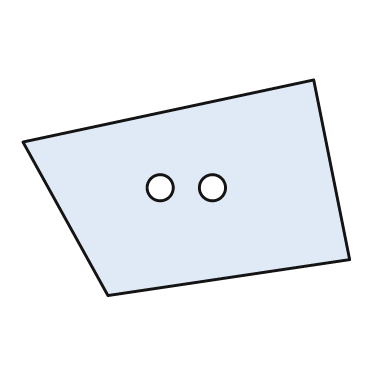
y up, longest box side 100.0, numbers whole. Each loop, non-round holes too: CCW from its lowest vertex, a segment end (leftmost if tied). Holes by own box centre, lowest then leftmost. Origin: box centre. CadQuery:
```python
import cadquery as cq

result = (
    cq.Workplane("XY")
    .moveTo(-24.0, -33.0)
    .lineTo(50.0, -22.0)
    .lineTo(39.0, 33.0)
    .lineTo(-50.0, 14.0)
    .close()
    .moveTo(-8.0, 0.0)
    .circle(4.0)
    .moveTo(8.0, 0.0)
    .circle(4.0)
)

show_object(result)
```